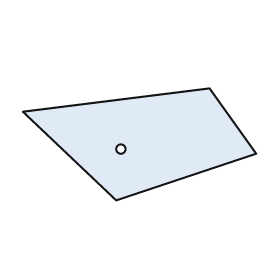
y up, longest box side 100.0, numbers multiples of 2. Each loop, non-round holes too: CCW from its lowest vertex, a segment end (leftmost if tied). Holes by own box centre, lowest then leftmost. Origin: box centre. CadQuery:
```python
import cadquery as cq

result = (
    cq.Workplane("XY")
    .moveTo(-10.0, -24.0)
    .lineTo(50.0, -4.0)
    .lineTo(30.0, 24.0)
    .lineTo(-50.0, 14.0)
    .close()
    .moveTo(-8.0, -2.0)
    .circle(2.0)
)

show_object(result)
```